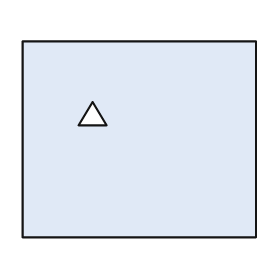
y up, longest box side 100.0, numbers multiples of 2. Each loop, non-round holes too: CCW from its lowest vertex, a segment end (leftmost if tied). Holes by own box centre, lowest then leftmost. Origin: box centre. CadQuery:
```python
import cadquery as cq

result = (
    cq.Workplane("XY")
    .moveTo(-50.0, -42.0)
    .lineTo(50.0, -42.0)
    .lineTo(50.0, 42.0)
    .lineTo(-50.0, 42.0)
    .close()
    .moveTo(-26.0, 6.0)
    .lineTo(-14.0, 6.0)
    .lineTo(-20.0, 16.0)
    .close()
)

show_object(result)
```